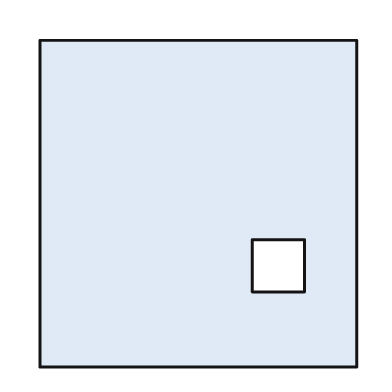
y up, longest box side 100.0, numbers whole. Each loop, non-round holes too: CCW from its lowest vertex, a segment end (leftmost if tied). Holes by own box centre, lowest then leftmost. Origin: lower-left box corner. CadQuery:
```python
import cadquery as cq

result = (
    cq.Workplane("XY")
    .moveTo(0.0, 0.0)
    .lineTo(97.0, 0.0)
    .lineTo(97.0, 100.0)
    .lineTo(0.0, 100.0)
    .close()
    .moveTo(65.0, 23.0)
    .lineTo(81.0, 23.0)
    .lineTo(81.0, 39.0)
    .lineTo(65.0, 39.0)
    .close()
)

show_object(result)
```